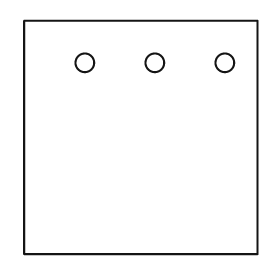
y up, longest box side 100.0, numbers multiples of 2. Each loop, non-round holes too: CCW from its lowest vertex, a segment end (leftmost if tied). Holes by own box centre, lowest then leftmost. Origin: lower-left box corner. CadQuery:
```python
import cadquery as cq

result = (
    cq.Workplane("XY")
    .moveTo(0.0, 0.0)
    .lineTo(100.0, 0.0)
    .lineTo(100.0, 100.0)
    .lineTo(0.0, 100.0)
    .close()
    .moveTo(26.0, 82.0)
    .circle(4.0)
    .moveTo(56.0, 82.0)
    .circle(4.0)
    .moveTo(86.0, 82.0)
    .circle(4.0)
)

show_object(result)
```